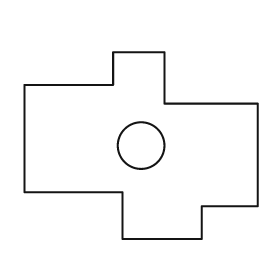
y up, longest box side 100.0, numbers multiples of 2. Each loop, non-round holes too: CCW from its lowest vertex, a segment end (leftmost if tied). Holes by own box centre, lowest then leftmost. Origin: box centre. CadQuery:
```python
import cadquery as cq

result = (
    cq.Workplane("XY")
    .moveTo(-8.0, -40.0)
    .lineTo(26.0, -40.0)
    .lineTo(26.0, -26.0)
    .lineTo(50.0, -26.0)
    .lineTo(50.0, 18.0)
    .lineTo(10.0, 18.0)
    .lineTo(10.0, 40.0)
    .lineTo(-12.0, 40.0)
    .lineTo(-12.0, 26.0)
    .lineTo(-50.0, 26.0)
    .lineTo(-50.0, -20.0)
    .lineTo(-8.0, -20.0)
    .close()
    .moveTo(0.0, 0.0)
    .circle(10.0)
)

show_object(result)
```